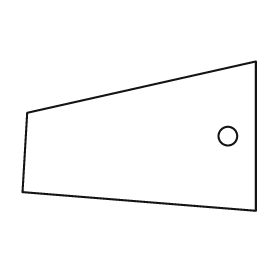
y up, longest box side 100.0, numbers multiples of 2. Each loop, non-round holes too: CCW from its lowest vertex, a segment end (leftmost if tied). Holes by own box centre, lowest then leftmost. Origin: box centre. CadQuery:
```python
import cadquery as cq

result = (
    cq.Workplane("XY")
    .moveTo(50.0, -32.0)
    .lineTo(50.0, 32.0)
    .lineTo(-48.0, 10.0)
    .lineTo(-50.0, -24.0)
    .close()
    .moveTo(38.0, 0.0)
    .circle(4.0)
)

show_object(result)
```